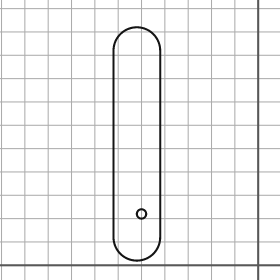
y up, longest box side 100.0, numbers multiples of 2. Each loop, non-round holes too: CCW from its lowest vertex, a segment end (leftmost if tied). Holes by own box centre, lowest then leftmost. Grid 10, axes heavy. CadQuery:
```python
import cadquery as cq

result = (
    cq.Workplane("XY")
    .moveTo(-62.0, 12.0)
    .threePointArc((-52.0, 2.0), (-42.0, 12.0))
    .lineTo(-42.0, 92.0)
    .threePointArc((-52.0, 102.0), (-62.0, 92.0))
    .close()
    .moveTo(-50.0, 22.0)
    .circle(2.0)
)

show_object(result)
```